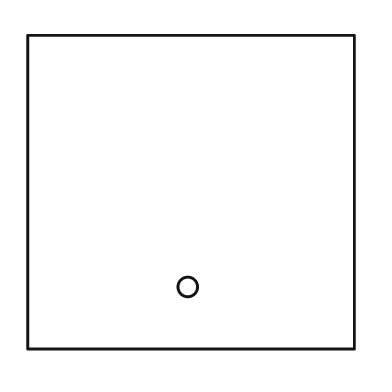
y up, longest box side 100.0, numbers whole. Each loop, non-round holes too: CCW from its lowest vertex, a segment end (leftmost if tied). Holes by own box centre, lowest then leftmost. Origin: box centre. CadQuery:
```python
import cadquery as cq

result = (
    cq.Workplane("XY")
    .moveTo(-50.0, -48.0)
    .lineTo(50.0, -48.0)
    .lineTo(50.0, 48.0)
    .lineTo(-50.0, 48.0)
    .close()
    .moveTo(-1.0, -29.0)
    .circle(3.0)
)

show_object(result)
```